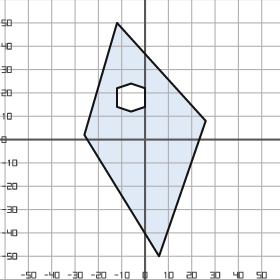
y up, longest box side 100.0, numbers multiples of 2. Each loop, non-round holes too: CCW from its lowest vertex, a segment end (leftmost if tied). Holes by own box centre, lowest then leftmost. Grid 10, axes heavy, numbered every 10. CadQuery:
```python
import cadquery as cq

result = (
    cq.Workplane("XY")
    .moveTo(6.0, -50.0)
    .lineTo(26.0, 8.0)
    .lineTo(-12.0, 50.0)
    .lineTo(-26.0, 2.0)
    .close()
    .moveTo(-6.0, 12.0)
    .lineTo(0.0, 14.0)
    .lineTo(0.0, 22.0)
    .lineTo(-6.0, 24.0)
    .lineTo(-12.0, 22.0)
    .lineTo(-12.0, 14.0)
    .close()
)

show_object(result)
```